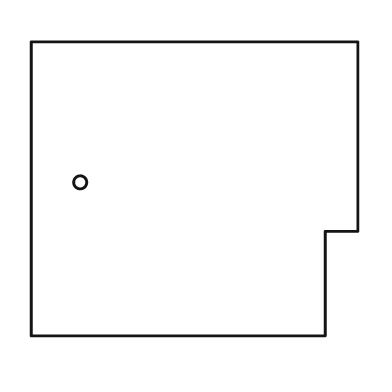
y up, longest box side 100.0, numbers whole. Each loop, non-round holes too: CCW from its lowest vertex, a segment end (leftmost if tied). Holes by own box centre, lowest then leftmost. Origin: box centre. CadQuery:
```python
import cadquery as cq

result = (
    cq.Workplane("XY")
    .moveTo(-50.0, -45.0)
    .lineTo(40.0, -45.0)
    .lineTo(40.0, -13.0)
    .lineTo(50.0, -13.0)
    .lineTo(50.0, 45.0)
    .lineTo(-50.0, 45.0)
    .close()
    .moveTo(-35.0, 2.0)
    .circle(2.0)
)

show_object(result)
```